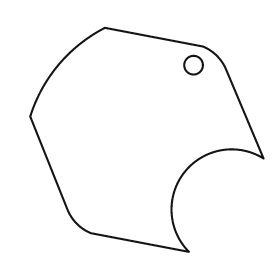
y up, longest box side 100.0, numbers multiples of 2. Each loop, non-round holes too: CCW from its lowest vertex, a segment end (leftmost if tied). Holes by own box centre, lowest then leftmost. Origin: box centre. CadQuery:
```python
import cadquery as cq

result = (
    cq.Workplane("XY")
    .moveTo(18.0, -48.0)
    .threePointArc((16.0, -14.0), (50.0, -8.0))
    .lineTo(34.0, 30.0)
    .threePointArc((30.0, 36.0), (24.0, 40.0))
    .lineTo(-18.0, 48.0)
    .threePointArc((-38.0, 32.0), (-50.0, 10.0))
    .lineTo(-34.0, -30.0)
    .threePointArc((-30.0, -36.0), (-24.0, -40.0))
    .close()
    .moveTo(20.0, 32.0)
    .circle(4.0)
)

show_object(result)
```